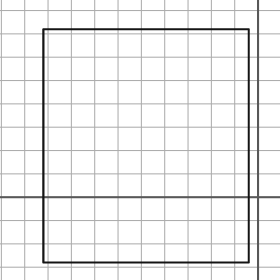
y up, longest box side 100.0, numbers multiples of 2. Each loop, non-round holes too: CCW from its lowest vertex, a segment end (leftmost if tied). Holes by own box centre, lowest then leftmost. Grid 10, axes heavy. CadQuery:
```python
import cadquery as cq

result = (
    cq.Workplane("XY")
    .moveTo(-92.0, -28.0)
    .lineTo(-4.0, -28.0)
    .lineTo(-4.0, 72.0)
    .lineTo(-92.0, 72.0)
    .close()
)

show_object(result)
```